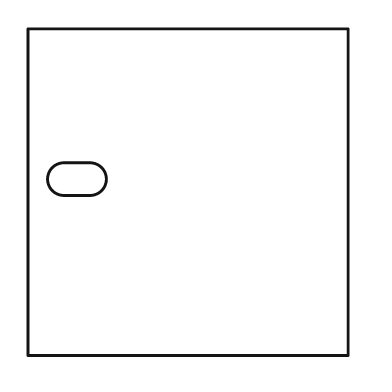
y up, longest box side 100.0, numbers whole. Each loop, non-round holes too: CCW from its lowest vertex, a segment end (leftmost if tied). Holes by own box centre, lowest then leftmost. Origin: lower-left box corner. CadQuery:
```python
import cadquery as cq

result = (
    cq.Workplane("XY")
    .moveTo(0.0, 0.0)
    .lineTo(98.0, 0.0)
    .lineTo(98.0, 100.0)
    .lineTo(0.0, 100.0)
    .close()
    .moveTo(11.0, 49.0)
    .lineTo(19.0, 49.0)
    .threePointArc((24.0, 54.0), (19.0, 59.0))
    .lineTo(11.0, 59.0)
    .threePointArc((6.0, 54.0), (11.0, 49.0))
    .close()
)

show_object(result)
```